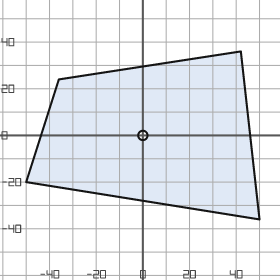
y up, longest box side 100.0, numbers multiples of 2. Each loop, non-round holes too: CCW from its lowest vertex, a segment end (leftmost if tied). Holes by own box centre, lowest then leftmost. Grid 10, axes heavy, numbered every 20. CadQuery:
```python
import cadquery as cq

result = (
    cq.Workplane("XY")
    .moveTo(50.0, -36.0)
    .lineTo(42.0, 36.0)
    .lineTo(-36.0, 24.0)
    .lineTo(-50.0, -20.0)
    .close()
    .moveTo(0.0, 0.0)
    .circle(2.0)
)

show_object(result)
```